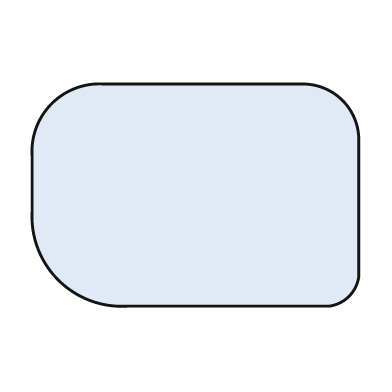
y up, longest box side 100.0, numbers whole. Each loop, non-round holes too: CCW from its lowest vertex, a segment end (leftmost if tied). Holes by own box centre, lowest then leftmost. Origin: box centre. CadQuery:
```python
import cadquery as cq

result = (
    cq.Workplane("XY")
    .moveTo(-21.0, -34.0)
    .lineTo(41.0, -34.0)
    .threePointArc((47.0, -31.0), (50.0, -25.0))
    .lineTo(50.0, 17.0)
    .threePointArc((45.0, 29.0), (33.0, 34.0))
    .lineTo(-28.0, 34.0)
    .threePointArc((-44.0, 28.0), (-50.0, 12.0))
    .lineTo(-50.0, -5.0)
    .threePointArc((-42.0, -26.0), (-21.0, -34.0))
    .close()
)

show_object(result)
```